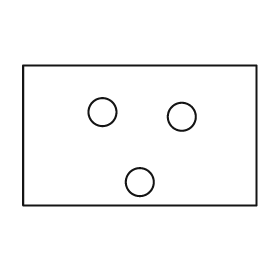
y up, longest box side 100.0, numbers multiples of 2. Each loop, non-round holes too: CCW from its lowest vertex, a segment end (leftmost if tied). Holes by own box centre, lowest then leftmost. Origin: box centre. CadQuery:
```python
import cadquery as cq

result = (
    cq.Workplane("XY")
    .moveTo(-50.0, -30.0)
    .lineTo(50.0, -30.0)
    .lineTo(50.0, 30.0)
    .lineTo(-50.0, 30.0)
    .close()
    .moveTo(0.0, -20.0)
    .circle(6.0)
    .moveTo(18.0, 8.0)
    .circle(6.0)
    .moveTo(-16.0, 10.0)
    .circle(6.0)
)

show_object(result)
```